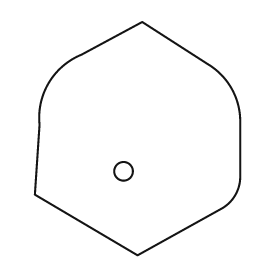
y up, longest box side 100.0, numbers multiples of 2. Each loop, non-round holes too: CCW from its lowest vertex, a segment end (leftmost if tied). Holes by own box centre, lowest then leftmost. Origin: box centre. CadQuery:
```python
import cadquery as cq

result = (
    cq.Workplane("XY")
    .moveTo(0.0, -50.0)
    .lineTo(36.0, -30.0)
    .threePointArc((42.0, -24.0), (44.0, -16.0))
    .lineTo(44.0, 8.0)
    .threePointArc((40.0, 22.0), (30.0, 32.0))
    .lineTo(2.0, 50.0)
    .lineTo(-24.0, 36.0)
    .threePointArc((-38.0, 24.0), (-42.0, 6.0))
    .lineTo(-44.0, -24.0)
    .close()
    .moveTo(-6.0, -14.0)
    .circle(4.0)
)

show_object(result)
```